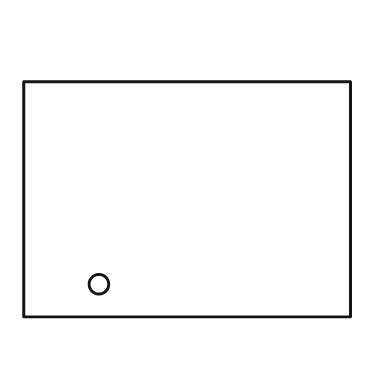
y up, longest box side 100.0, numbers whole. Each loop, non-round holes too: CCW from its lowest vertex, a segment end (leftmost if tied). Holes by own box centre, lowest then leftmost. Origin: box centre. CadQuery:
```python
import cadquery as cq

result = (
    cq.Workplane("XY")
    .moveTo(-50.0, -36.0)
    .lineTo(50.0, -36.0)
    .lineTo(50.0, 36.0)
    .lineTo(-50.0, 36.0)
    .close()
    .moveTo(-27.0, -26.0)
    .circle(3.0)
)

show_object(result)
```